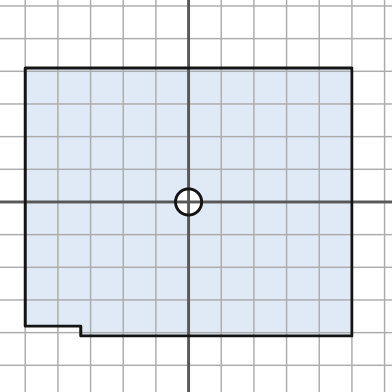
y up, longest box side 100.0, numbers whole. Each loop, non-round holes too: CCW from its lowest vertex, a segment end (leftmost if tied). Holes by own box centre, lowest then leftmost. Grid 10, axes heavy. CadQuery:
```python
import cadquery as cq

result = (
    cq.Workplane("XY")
    .moveTo(-33.0, -41.0)
    .lineTo(50.0, -41.0)
    .lineTo(50.0, 41.0)
    .lineTo(-50.0, 41.0)
    .lineTo(-50.0, -38.0)
    .lineTo(-33.0, -38.0)
    .close()
    .moveTo(0.0, 0.0)
    .circle(4.0)
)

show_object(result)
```